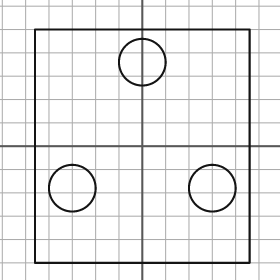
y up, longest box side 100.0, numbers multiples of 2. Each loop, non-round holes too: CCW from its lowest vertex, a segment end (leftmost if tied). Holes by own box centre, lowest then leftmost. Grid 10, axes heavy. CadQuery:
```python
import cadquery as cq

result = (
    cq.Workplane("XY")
    .moveTo(-46.0, -50.0)
    .lineTo(46.0, -50.0)
    .lineTo(46.0, 50.0)
    .lineTo(-46.0, 50.0)
    .close()
    .moveTo(-30.0, -18.0)
    .circle(10.0)
    .moveTo(30.0, -18.0)
    .circle(10.0)
    .moveTo(0.0, 36.0)
    .circle(10.0)
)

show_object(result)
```